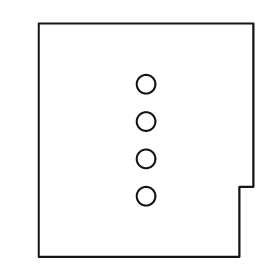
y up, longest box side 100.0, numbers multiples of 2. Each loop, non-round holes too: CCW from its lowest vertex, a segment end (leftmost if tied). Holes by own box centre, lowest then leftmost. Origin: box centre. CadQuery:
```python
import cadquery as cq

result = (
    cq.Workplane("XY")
    .moveTo(-46.0, -50.0)
    .lineTo(40.0, -50.0)
    .lineTo(40.0, -20.0)
    .lineTo(46.0, -20.0)
    .lineTo(46.0, 50.0)
    .lineTo(-46.0, 50.0)
    .close()
    .moveTo(0.0, -24.0)
    .circle(4.0)
    .moveTo(0.0, -8.0)
    .circle(4.0)
    .moveTo(0.0, 8.0)
    .circle(4.0)
    .moveTo(0.0, 24.0)
    .circle(4.0)
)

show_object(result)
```